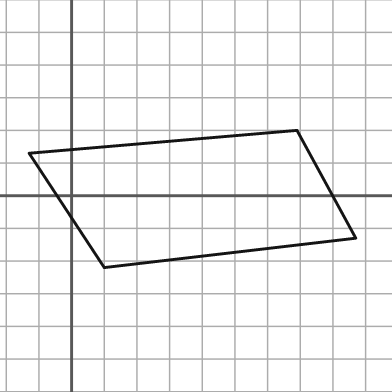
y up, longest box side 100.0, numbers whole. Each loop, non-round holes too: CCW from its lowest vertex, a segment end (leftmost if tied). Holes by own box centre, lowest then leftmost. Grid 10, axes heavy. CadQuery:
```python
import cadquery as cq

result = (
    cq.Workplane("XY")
    .moveTo(10.0, -22.0)
    .lineTo(87.0, -13.0)
    .lineTo(69.0, 20.0)
    .lineTo(-13.0, 13.0)
    .close()
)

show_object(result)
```